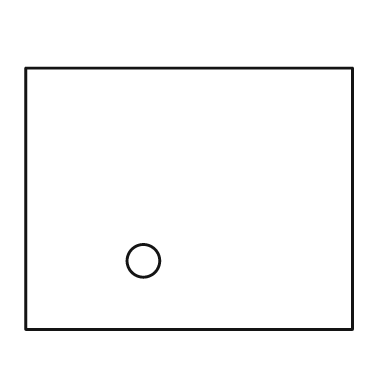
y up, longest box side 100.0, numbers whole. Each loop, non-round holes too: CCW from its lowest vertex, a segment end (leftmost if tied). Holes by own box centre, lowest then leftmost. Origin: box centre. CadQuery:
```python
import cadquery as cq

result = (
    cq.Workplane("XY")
    .moveTo(-50.0, -40.0)
    .lineTo(50.0, -40.0)
    .lineTo(50.0, 40.0)
    .lineTo(-50.0, 40.0)
    .close()
    .moveTo(-14.0, -19.0)
    .circle(5.0)
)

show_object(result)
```